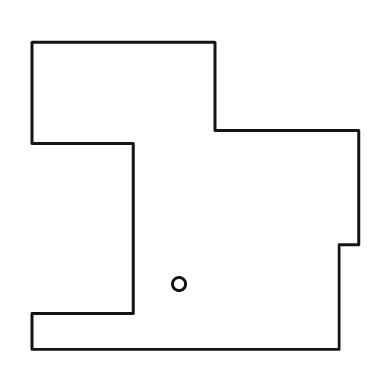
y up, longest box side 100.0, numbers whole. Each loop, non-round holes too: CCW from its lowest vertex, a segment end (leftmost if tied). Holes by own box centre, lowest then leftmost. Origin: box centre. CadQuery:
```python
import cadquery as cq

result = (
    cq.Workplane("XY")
    .moveTo(-50.0, -47.0)
    .lineTo(44.0, -47.0)
    .lineTo(44.0, -15.0)
    .lineTo(50.0, -15.0)
    .lineTo(50.0, 20.0)
    .lineTo(6.0, 20.0)
    .lineTo(6.0, 47.0)
    .lineTo(-50.0, 47.0)
    .lineTo(-50.0, 16.0)
    .lineTo(-19.0, 16.0)
    .lineTo(-19.0, -36.0)
    .lineTo(-50.0, -36.0)
    .close()
    .moveTo(-5.0, -27.0)
    .circle(2.0)
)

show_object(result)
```